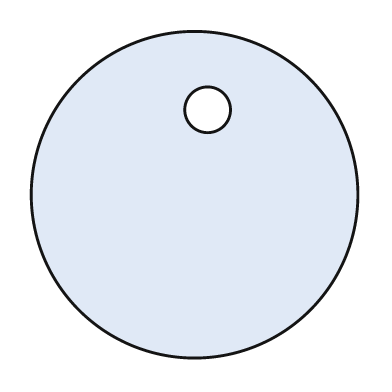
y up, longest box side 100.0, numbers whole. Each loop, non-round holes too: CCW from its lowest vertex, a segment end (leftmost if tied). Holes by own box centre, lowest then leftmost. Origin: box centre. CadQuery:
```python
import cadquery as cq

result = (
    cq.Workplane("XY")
    .moveTo(0.0, 0.0)
    .circle(50.0)
    .moveTo(4.0, 26.0)
    .circle(7.0)
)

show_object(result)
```